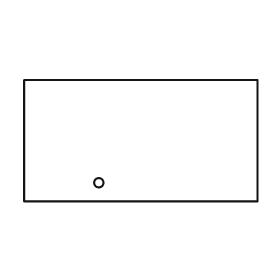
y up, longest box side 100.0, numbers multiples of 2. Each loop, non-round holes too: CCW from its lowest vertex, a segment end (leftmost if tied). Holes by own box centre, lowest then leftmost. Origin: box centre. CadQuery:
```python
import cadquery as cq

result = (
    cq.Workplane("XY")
    .moveTo(-50.0, -26.0)
    .lineTo(50.0, -26.0)
    .lineTo(50.0, 26.0)
    .lineTo(-50.0, 26.0)
    .close()
    .moveTo(-18.0, -18.0)
    .circle(2.0)
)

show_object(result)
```